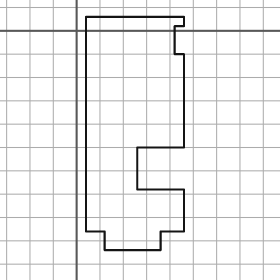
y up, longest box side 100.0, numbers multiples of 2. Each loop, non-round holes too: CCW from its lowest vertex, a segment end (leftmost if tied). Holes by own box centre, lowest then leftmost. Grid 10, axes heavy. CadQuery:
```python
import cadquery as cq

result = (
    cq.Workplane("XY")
    .moveTo(12.0, -94.0)
    .lineTo(36.0, -94.0)
    .lineTo(36.0, -86.0)
    .lineTo(46.0, -86.0)
    .lineTo(46.0, -68.0)
    .lineTo(26.0, -68.0)
    .lineTo(26.0, -50.0)
    .lineTo(46.0, -50.0)
    .lineTo(46.0, -10.0)
    .lineTo(42.0, -10.0)
    .lineTo(42.0, 2.0)
    .lineTo(46.0, 2.0)
    .lineTo(46.0, 6.0)
    .lineTo(4.0, 6.0)
    .lineTo(4.0, -86.0)
    .lineTo(12.0, -86.0)
    .close()
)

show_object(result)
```